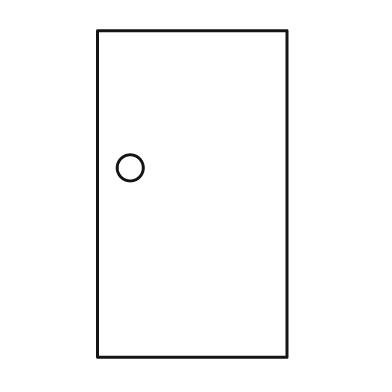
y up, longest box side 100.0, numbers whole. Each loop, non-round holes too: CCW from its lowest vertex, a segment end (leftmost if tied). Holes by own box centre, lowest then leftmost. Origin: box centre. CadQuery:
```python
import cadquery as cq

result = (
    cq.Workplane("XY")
    .moveTo(-29.0, -50.0)
    .lineTo(29.0, -50.0)
    .lineTo(29.0, 50.0)
    .lineTo(-29.0, 50.0)
    .close()
    .moveTo(-19.0, 8.0)
    .circle(4.0)
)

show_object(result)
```